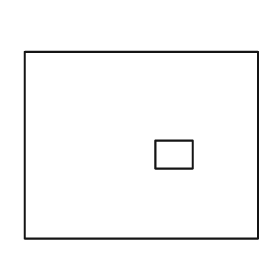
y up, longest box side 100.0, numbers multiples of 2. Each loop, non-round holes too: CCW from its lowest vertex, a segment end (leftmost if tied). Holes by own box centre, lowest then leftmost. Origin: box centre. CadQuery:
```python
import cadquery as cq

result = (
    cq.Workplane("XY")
    .moveTo(-50.0, -40.0)
    .lineTo(50.0, -40.0)
    .lineTo(50.0, 40.0)
    .lineTo(-50.0, 40.0)
    .close()
    .moveTo(6.0, -10.0)
    .lineTo(22.0, -10.0)
    .lineTo(22.0, 2.0)
    .lineTo(6.0, 2.0)
    .close()
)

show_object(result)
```